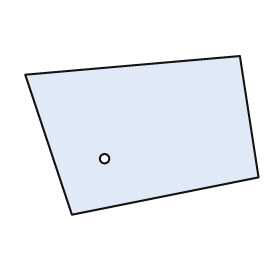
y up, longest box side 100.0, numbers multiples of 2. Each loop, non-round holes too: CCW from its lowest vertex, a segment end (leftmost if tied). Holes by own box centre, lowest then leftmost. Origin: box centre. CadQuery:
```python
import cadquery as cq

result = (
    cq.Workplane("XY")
    .moveTo(-30.0, -34.0)
    .lineTo(50.0, -18.0)
    .lineTo(42.0, 34.0)
    .lineTo(-50.0, 26.0)
    .close()
    .moveTo(-16.0, -10.0)
    .circle(2.0)
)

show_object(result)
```